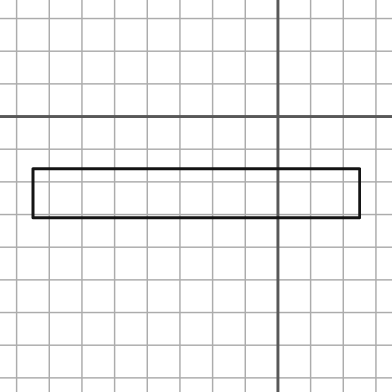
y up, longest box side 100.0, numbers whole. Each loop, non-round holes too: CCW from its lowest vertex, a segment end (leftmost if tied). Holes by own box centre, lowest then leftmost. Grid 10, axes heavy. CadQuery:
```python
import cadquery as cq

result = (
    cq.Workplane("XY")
    .moveTo(-75.0, -31.0)
    .lineTo(25.0, -31.0)
    .lineTo(25.0, -16.0)
    .lineTo(-75.0, -16.0)
    .close()
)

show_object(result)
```